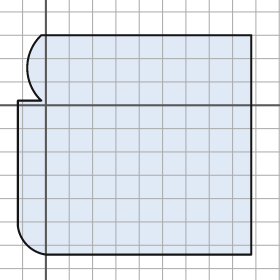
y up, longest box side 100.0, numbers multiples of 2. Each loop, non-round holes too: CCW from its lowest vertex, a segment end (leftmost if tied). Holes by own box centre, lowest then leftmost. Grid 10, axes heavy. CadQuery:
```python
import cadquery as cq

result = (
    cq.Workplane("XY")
    .moveTo(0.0, -64.0)
    .lineTo(88.0, -64.0)
    .lineTo(88.0, 30.0)
    .lineTo(-2.0, 30.0)
    .threePointArc((-8.0, 16.0), (-2.0, 2.0))
    .lineTo(-12.0, 2.0)
    .lineTo(-12.0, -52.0)
    .threePointArc((-8.0, -60.0), (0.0, -64.0))
    .close()
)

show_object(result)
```